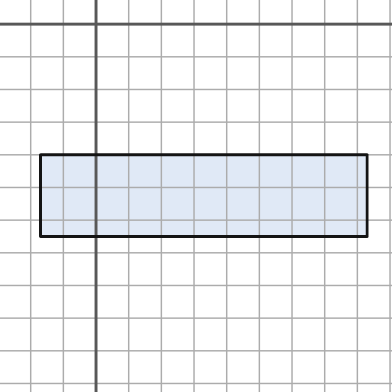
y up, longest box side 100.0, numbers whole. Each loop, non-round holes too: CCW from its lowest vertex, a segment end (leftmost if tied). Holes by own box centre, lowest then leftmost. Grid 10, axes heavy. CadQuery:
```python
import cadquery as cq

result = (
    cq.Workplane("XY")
    .moveTo(-17.0, -65.0)
    .lineTo(83.0, -65.0)
    .lineTo(83.0, -40.0)
    .lineTo(-17.0, -40.0)
    .close()
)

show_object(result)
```